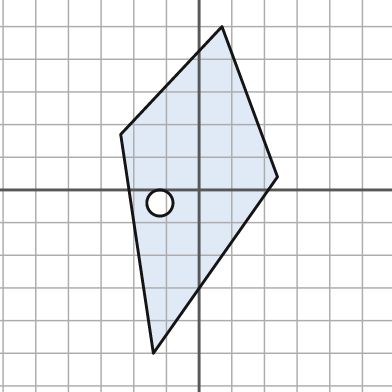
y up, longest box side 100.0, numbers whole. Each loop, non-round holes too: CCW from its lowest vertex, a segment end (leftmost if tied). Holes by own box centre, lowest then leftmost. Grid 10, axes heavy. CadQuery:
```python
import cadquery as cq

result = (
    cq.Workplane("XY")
    .moveTo(-14.0, -50.0)
    .lineTo(24.0, 4.0)
    .lineTo(7.0, 50.0)
    .lineTo(-24.0, 17.0)
    .close()
    .moveTo(-12.0, -4.0)
    .circle(4.0)
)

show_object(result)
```